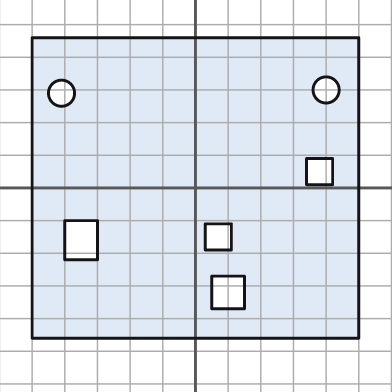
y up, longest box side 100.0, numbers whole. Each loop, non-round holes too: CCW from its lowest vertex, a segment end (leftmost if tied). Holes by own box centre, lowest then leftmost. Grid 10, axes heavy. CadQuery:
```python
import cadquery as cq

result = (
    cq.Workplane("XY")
    .moveTo(-50.0, -46.0)
    .lineTo(50.0, -46.0)
    .lineTo(50.0, 46.0)
    .lineTo(-50.0, 46.0)
    .close()
    .moveTo(5.0, -37.0)
    .lineTo(15.0, -37.0)
    .lineTo(15.0, -27.0)
    .lineTo(5.0, -27.0)
    .close()
    .moveTo(-40.0, -22.0)
    .lineTo(-30.0, -22.0)
    .lineTo(-30.0, -10.0)
    .lineTo(-40.0, -10.0)
    .close()
    .moveTo(3.0, -19.0)
    .lineTo(11.0, -19.0)
    .lineTo(11.0, -11.0)
    .lineTo(3.0, -11.0)
    .close()
    .moveTo(34.0, 1.0)
    .lineTo(42.0, 1.0)
    .lineTo(42.0, 9.0)
    .lineTo(34.0, 9.0)
    .close()
    .moveTo(-41.0, 29.0)
    .circle(4.0)
    .moveTo(40.0, 30.0)
    .circle(4.0)
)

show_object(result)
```